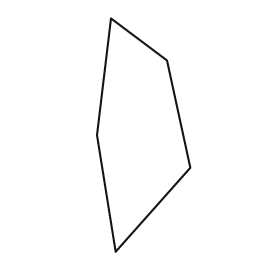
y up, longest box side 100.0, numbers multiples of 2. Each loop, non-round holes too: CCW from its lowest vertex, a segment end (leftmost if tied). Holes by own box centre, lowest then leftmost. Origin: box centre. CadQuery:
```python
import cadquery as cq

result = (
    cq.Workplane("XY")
    .moveTo(-12.0, -50.0)
    .lineTo(20.0, -14.0)
    .lineTo(10.0, 32.0)
    .lineTo(-14.0, 50.0)
    .lineTo(-20.0, 0.0)
    .close()
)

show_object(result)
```